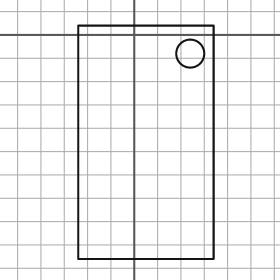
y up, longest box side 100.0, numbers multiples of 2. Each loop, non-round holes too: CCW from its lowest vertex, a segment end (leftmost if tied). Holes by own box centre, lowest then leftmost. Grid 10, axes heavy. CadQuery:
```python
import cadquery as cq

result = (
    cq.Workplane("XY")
    .moveTo(-24.0, -96.0)
    .lineTo(34.0, -96.0)
    .lineTo(34.0, 4.0)
    .lineTo(-24.0, 4.0)
    .close()
    .moveTo(24.0, -8.0)
    .circle(6.0)
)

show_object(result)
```